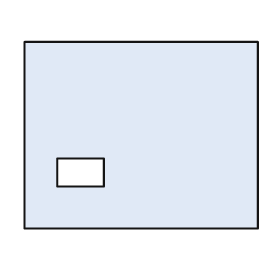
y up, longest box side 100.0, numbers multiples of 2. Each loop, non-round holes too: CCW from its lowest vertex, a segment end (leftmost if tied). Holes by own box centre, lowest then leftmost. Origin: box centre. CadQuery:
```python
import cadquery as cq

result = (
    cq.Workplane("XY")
    .moveTo(-50.0, -40.0)
    .lineTo(50.0, -40.0)
    .lineTo(50.0, 40.0)
    .lineTo(-50.0, 40.0)
    .close()
    .moveTo(-36.0, -22.0)
    .lineTo(-16.0, -22.0)
    .lineTo(-16.0, -10.0)
    .lineTo(-36.0, -10.0)
    .close()
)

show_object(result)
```